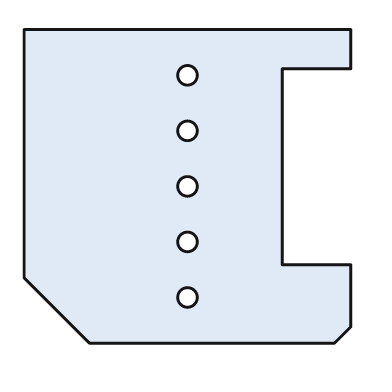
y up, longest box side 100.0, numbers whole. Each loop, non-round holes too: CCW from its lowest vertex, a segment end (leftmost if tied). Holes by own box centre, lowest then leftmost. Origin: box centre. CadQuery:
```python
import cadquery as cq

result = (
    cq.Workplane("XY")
    .moveTo(-30.0, -48.0)
    .lineTo(45.0, -48.0)
    .lineTo(50.0, -43.0)
    .lineTo(50.0, -24.0)
    .lineTo(29.0, -24.0)
    .lineTo(29.0, 36.0)
    .lineTo(50.0, 36.0)
    .lineTo(50.0, 48.0)
    .lineTo(-50.0, 48.0)
    .lineTo(-50.0, -28.0)
    .close()
    .moveTo(0.0, -34.0)
    .circle(3.0)
    .moveTo(0.0, -17.0)
    .circle(3.0)
    .moveTo(0.0, 0.0)
    .circle(3.0)
    .moveTo(0.0, 17.0)
    .circle(3.0)
    .moveTo(0.0, 34.0)
    .circle(3.0)
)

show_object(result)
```